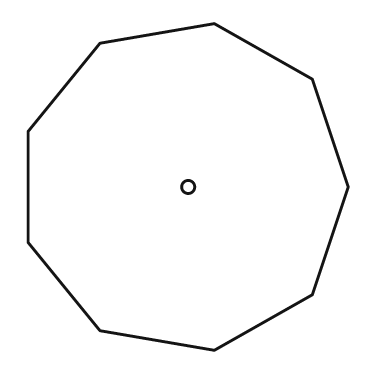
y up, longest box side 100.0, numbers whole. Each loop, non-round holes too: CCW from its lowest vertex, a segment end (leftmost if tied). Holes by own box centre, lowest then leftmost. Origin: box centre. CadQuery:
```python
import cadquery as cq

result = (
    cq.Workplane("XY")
    .moveTo(8.0, -50.0)
    .lineTo(38.0, -33.0)
    .lineTo(49.0, 0.0)
    .lineTo(38.0, 33.0)
    .lineTo(8.0, 50.0)
    .lineTo(-27.0, 44.0)
    .lineTo(-49.0, 17.0)
    .lineTo(-49.0, -17.0)
    .lineTo(-27.0, -44.0)
    .close()
    .moveTo(0.0, 0.0)
    .circle(2.0)
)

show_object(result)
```